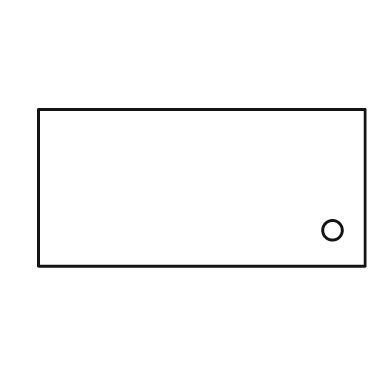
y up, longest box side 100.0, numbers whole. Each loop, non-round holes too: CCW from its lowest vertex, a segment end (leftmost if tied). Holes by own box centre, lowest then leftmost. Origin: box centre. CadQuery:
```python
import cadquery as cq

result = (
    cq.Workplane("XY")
    .moveTo(-50.0, -24.0)
    .lineTo(50.0, -24.0)
    .lineTo(50.0, 24.0)
    .lineTo(-50.0, 24.0)
    .close()
    .moveTo(40.0, -13.0)
    .circle(3.0)
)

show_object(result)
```